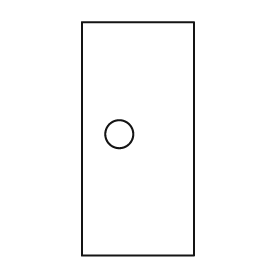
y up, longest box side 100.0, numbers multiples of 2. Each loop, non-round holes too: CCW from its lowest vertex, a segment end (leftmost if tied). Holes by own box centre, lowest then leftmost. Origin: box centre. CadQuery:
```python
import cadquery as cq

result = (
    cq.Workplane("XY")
    .moveTo(-24.0, -50.0)
    .lineTo(24.0, -50.0)
    .lineTo(24.0, 50.0)
    .lineTo(-24.0, 50.0)
    .close()
    .moveTo(-8.0, 2.0)
    .circle(6.0)
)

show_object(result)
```